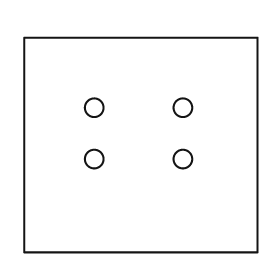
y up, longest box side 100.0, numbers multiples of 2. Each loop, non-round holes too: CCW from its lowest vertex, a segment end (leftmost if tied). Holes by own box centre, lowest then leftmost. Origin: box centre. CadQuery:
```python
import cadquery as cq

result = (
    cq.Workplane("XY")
    .moveTo(-50.0, -46.0)
    .lineTo(50.0, -46.0)
    .lineTo(50.0, 46.0)
    .lineTo(-50.0, 46.0)
    .close()
    .moveTo(-20.0, -6.0)
    .circle(4.0)
    .moveTo(18.0, -6.0)
    .circle(4.0)
    .moveTo(-20.0, 16.0)
    .circle(4.0)
    .moveTo(18.0, 16.0)
    .circle(4.0)
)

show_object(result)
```